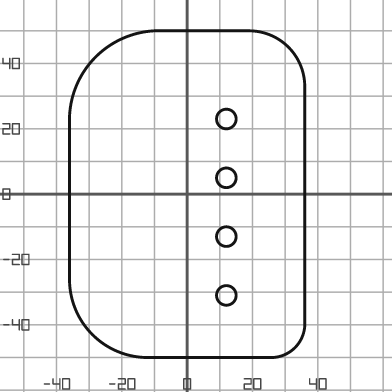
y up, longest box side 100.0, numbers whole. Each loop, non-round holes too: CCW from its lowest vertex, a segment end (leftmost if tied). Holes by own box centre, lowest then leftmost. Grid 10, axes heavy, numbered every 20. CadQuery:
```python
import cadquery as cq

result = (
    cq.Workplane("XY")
    .moveTo(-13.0, -50.0)
    .lineTo(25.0, -50.0)
    .threePointArc((33.0, -47.0), (36.0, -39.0))
    .lineTo(36.0, 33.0)
    .threePointArc((31.0, 45.0), (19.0, 50.0))
    .lineTo(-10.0, 50.0)
    .threePointArc((-28.0, 42.0), (-36.0, 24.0))
    .lineTo(-36.0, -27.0)
    .threePointArc((-29.0, -43.0), (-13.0, -50.0))
    .close()
    .moveTo(12.0, -31.0)
    .circle(3.0)
    .moveTo(12.0, -13.0)
    .circle(3.0)
    .moveTo(12.0, 5.0)
    .circle(3.0)
    .moveTo(12.0, 23.0)
    .circle(3.0)
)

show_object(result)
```